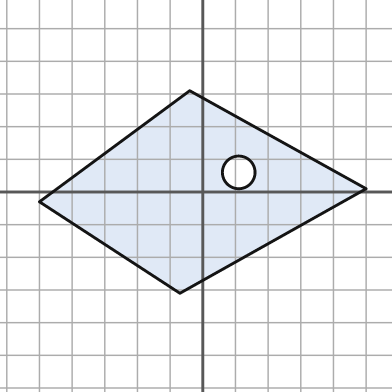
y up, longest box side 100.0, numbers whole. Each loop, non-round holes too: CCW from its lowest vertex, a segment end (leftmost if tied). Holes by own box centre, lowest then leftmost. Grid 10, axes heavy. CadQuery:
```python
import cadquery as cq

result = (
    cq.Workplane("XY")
    .moveTo(-7.0, -31.0)
    .lineTo(50.0, 1.0)
    .lineTo(-4.0, 31.0)
    .lineTo(-50.0, -3.0)
    .close()
    .moveTo(11.0, 6.0)
    .circle(5.0)
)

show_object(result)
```